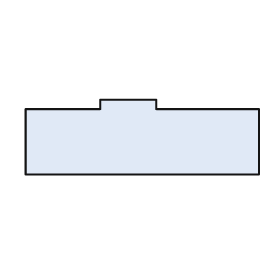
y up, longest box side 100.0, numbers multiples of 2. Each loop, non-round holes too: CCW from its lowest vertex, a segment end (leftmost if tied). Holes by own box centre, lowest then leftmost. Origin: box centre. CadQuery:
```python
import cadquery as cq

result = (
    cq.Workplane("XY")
    .moveTo(-50.0, -16.0)
    .lineTo(50.0, -16.0)
    .lineTo(50.0, 12.0)
    .lineTo(6.0, 12.0)
    .lineTo(6.0, 16.0)
    .lineTo(-18.0, 16.0)
    .lineTo(-18.0, 12.0)
    .lineTo(-50.0, 12.0)
    .close()
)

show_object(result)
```